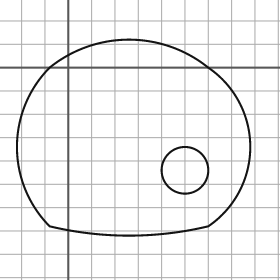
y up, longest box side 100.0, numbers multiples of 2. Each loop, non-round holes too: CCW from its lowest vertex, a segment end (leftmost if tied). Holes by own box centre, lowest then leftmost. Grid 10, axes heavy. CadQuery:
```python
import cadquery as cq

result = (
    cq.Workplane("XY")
    .moveTo(-8.0, -68.0)
    .threePointArc((26.0, -72.0), (60.0, -68.0))
    .threePointArc((78.0, -34.0), (60.0, 0.0))
    .threePointArc((26.0, 12.0), (-8.0, 0.0))
    .threePointArc((-22.0, -34.0), (-8.0, -68.0))
    .close()
    .moveTo(50.0, -44.0)
    .circle(10.0)
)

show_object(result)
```